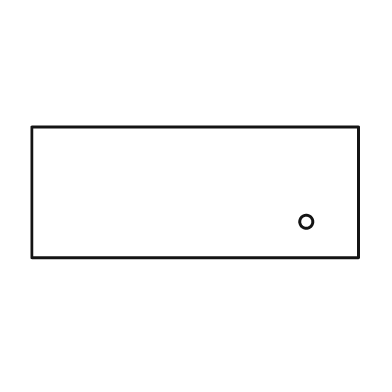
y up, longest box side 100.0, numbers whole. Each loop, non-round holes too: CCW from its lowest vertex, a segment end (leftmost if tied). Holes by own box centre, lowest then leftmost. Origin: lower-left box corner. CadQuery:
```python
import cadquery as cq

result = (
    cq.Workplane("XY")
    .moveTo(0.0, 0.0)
    .lineTo(100.0, 0.0)
    .lineTo(100.0, 40.0)
    .lineTo(0.0, 40.0)
    .close()
    .moveTo(84.0, 11.0)
    .circle(2.0)
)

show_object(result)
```